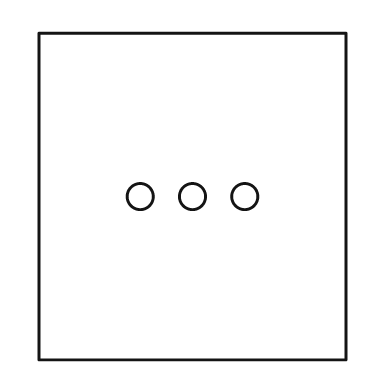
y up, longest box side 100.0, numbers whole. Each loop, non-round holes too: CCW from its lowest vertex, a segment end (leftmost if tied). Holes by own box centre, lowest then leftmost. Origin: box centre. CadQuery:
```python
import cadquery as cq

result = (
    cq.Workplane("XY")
    .moveTo(-47.0, -50.0)
    .lineTo(47.0, -50.0)
    .lineTo(47.0, 50.0)
    .lineTo(-47.0, 50.0)
    .close()
    .moveTo(-16.0, 0.0)
    .circle(4.0)
    .moveTo(0.0, 0.0)
    .circle(4.0)
    .moveTo(16.0, 0.0)
    .circle(4.0)
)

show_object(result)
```